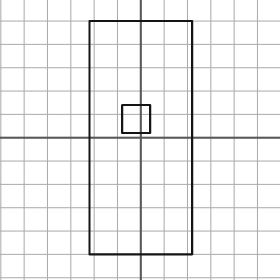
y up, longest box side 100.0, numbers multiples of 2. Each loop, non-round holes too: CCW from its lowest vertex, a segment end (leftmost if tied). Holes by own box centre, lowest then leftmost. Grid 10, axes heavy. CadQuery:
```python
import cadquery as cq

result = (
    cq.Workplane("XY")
    .moveTo(-22.0, -50.0)
    .lineTo(22.0, -50.0)
    .lineTo(22.0, 50.0)
    .lineTo(-22.0, 50.0)
    .close()
    .moveTo(-8.0, 2.0)
    .lineTo(4.0, 2.0)
    .lineTo(4.0, 14.0)
    .lineTo(-8.0, 14.0)
    .close()
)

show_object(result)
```